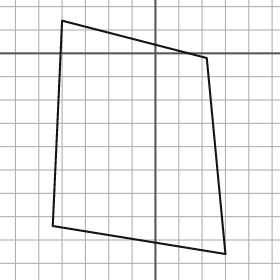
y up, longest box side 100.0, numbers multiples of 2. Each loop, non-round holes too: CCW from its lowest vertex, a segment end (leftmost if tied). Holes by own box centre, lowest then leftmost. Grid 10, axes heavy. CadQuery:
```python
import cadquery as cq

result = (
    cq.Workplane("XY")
    .moveTo(30.0, -86.0)
    .lineTo(22.0, -2.0)
    .lineTo(-40.0, 14.0)
    .lineTo(-44.0, -74.0)
    .close()
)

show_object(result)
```